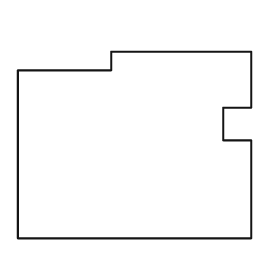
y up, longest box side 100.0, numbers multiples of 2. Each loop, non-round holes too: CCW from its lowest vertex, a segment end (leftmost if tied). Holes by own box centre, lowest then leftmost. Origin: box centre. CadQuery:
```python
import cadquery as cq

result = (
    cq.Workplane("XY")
    .moveTo(-50.0, -40.0)
    .lineTo(50.0, -40.0)
    .lineTo(50.0, 2.0)
    .lineTo(38.0, 2.0)
    .lineTo(38.0, 16.0)
    .lineTo(50.0, 16.0)
    .lineTo(50.0, 40.0)
    .lineTo(-10.0, 40.0)
    .lineTo(-10.0, 32.0)
    .lineTo(-50.0, 32.0)
    .close()
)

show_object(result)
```